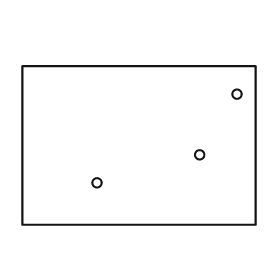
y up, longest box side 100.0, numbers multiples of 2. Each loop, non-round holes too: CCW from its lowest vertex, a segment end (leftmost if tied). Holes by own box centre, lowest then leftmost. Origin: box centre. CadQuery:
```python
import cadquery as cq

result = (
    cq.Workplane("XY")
    .moveTo(-50.0, -34.0)
    .lineTo(50.0, -34.0)
    .lineTo(50.0, 34.0)
    .lineTo(-50.0, 34.0)
    .close()
    .moveTo(-18.0, -16.0)
    .circle(2.0)
    .moveTo(26.0, -4.0)
    .circle(2.0)
    .moveTo(42.0, 22.0)
    .circle(2.0)
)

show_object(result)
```